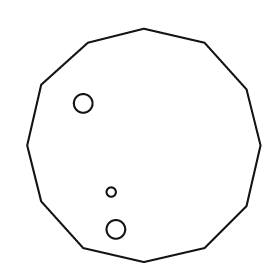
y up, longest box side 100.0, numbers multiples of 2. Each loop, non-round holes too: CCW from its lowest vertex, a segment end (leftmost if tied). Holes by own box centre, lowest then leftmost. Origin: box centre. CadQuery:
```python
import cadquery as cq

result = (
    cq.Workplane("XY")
    .moveTo(0.0, -50.0)
    .lineTo(26.0, -44.0)
    .lineTo(44.0, -26.0)
    .lineTo(50.0, 0.0)
    .lineTo(44.0, 24.0)
    .lineTo(26.0, 44.0)
    .lineTo(0.0, 50.0)
    .lineTo(-24.0, 44.0)
    .lineTo(-44.0, 26.0)
    .lineTo(-50.0, 0.0)
    .lineTo(-44.0, -24.0)
    .lineTo(-26.0, -44.0)
    .close()
    .moveTo(-12.0, -36.0)
    .circle(4.0)
    .moveTo(-14.0, -20.0)
    .circle(2.0)
    .moveTo(-26.0, 18.0)
    .circle(4.0)
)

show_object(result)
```